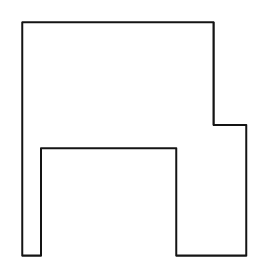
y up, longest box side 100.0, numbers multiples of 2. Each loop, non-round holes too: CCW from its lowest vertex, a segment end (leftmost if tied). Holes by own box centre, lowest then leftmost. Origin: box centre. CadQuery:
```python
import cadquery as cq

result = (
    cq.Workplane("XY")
    .moveTo(-48.0, -50.0)
    .lineTo(-40.0, -50.0)
    .lineTo(-40.0, -4.0)
    .lineTo(18.0, -4.0)
    .lineTo(18.0, -50.0)
    .lineTo(48.0, -50.0)
    .lineTo(48.0, 6.0)
    .lineTo(34.0, 6.0)
    .lineTo(34.0, 50.0)
    .lineTo(-48.0, 50.0)
    .close()
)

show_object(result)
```